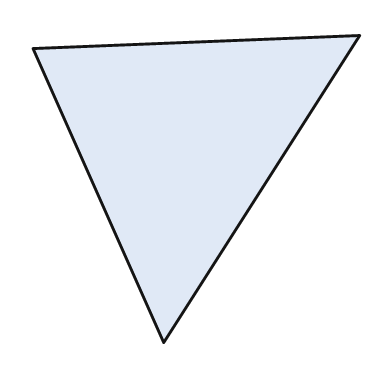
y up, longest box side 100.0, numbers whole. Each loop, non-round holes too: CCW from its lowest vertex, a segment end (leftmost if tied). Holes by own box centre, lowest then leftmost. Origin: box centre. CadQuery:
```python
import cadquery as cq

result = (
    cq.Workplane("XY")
    .moveTo(-10.0, -47.0)
    .lineTo(50.0, 47.0)
    .lineTo(-50.0, 43.0)
    .close()
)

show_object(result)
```